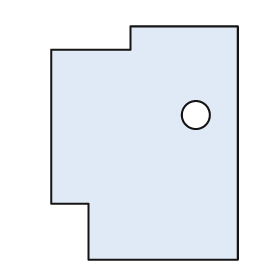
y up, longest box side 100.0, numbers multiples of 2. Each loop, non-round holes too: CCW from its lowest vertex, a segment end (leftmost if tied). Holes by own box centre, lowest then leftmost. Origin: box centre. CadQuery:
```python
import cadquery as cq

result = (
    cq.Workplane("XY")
    .moveTo(-24.0, -50.0)
    .lineTo(40.0, -50.0)
    .lineTo(40.0, 50.0)
    .lineTo(-6.0, 50.0)
    .lineTo(-6.0, 40.0)
    .lineTo(-40.0, 40.0)
    .lineTo(-40.0, -26.0)
    .lineTo(-24.0, -26.0)
    .close()
    .moveTo(22.0, 12.0)
    .circle(6.0)
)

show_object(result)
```